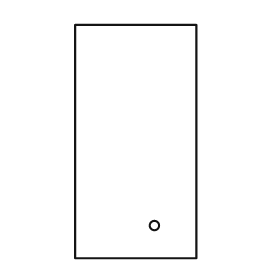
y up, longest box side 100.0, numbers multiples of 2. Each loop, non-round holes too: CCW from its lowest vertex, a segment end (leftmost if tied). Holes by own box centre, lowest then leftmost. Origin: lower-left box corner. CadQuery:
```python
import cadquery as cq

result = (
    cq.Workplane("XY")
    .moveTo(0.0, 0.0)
    .lineTo(52.0, 0.0)
    .lineTo(52.0, 100.0)
    .lineTo(0.0, 100.0)
    .close()
    .moveTo(34.0, 14.0)
    .circle(2.0)
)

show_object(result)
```